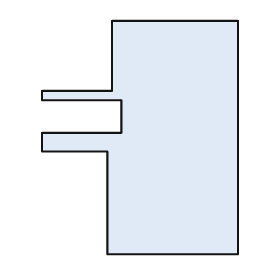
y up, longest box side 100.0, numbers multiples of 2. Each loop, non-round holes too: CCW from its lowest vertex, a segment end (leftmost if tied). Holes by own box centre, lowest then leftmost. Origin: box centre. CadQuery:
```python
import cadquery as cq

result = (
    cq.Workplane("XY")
    .moveTo(-14.0, -50.0)
    .lineTo(42.0, -50.0)
    .lineTo(42.0, 50.0)
    .lineTo(-12.0, 50.0)
    .lineTo(-12.0, 20.0)
    .lineTo(-42.0, 20.0)
    .lineTo(-42.0, 16.0)
    .lineTo(-8.0, 16.0)
    .lineTo(-8.0, 2.0)
    .lineTo(-42.0, 2.0)
    .lineTo(-42.0, -6.0)
    .lineTo(-14.0, -6.0)
    .close()
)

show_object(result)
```